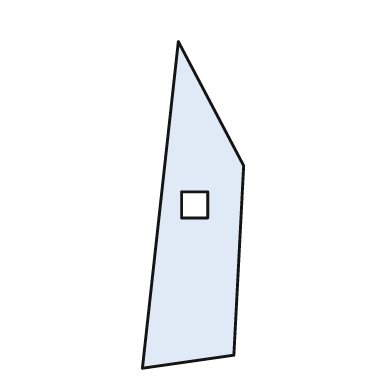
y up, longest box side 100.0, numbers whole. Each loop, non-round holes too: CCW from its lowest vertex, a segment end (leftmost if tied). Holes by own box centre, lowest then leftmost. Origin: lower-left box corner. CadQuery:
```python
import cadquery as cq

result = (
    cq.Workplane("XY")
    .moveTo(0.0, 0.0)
    .lineTo(28.0, 4.0)
    .lineTo(31.0, 62.0)
    .lineTo(11.0, 100.0)
    .close()
    .moveTo(12.0, 46.0)
    .lineTo(20.0, 46.0)
    .lineTo(20.0, 54.0)
    .lineTo(12.0, 54.0)
    .close()
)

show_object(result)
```